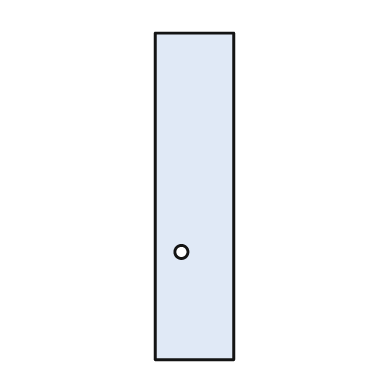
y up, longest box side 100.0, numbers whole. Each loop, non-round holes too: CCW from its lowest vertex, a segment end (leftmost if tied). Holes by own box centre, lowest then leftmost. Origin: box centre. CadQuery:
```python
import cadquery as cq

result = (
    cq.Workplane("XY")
    .moveTo(-12.0, -50.0)
    .lineTo(12.0, -50.0)
    .lineTo(12.0, 50.0)
    .lineTo(-12.0, 50.0)
    .close()
    .moveTo(-4.0, -17.0)
    .circle(2.0)
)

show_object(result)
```